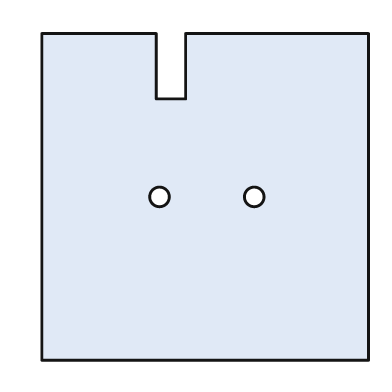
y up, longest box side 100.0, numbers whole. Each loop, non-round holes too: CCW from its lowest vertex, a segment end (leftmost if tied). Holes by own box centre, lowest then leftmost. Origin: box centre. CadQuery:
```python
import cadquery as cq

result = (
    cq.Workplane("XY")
    .moveTo(-50.0, -50.0)
    .lineTo(50.0, -50.0)
    .lineTo(50.0, 50.0)
    .lineTo(-6.0, 50.0)
    .lineTo(-6.0, 30.0)
    .lineTo(-15.0, 30.0)
    .lineTo(-15.0, 50.0)
    .lineTo(-50.0, 50.0)
    .close()
    .moveTo(-14.0, 0.0)
    .circle(3.0)
    .moveTo(15.0, 0.0)
    .circle(3.0)
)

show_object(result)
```